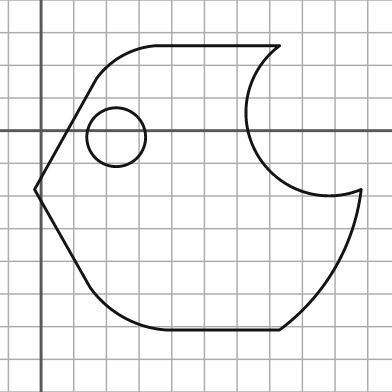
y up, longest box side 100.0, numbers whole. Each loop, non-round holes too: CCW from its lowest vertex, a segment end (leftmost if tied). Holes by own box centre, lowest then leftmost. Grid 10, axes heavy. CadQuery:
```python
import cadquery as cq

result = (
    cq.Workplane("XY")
    .moveTo(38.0, -61.0)
    .lineTo(73.0, -61.0)
    .threePointArc((90.0, -42.0), (98.0, -18.0))
    .threePointArc((66.0, -7.0), (73.0, 26.0))
    .lineTo(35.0, 26.0)
    .threePointArc((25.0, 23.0), (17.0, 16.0))
    .lineTo(-2.0, -18.0)
    .lineTo(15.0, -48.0)
    .threePointArc((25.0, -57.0), (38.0, -61.0))
    .close()
    .moveTo(23.0, -2.0)
    .circle(9.0)
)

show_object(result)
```